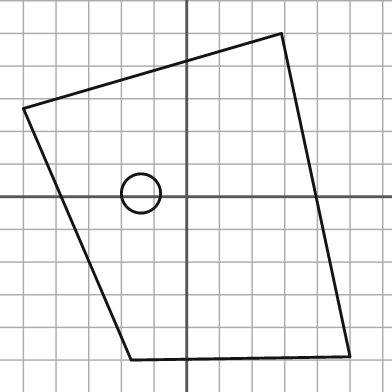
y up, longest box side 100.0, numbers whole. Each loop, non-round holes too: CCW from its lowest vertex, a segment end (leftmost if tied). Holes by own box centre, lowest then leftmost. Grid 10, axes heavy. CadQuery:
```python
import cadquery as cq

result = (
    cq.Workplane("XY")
    .moveTo(-17.0, -50.0)
    .lineTo(50.0, -49.0)
    .lineTo(29.0, 50.0)
    .lineTo(-50.0, 27.0)
    .close()
    .moveTo(-14.0, 1.0)
    .circle(6.0)
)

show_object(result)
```